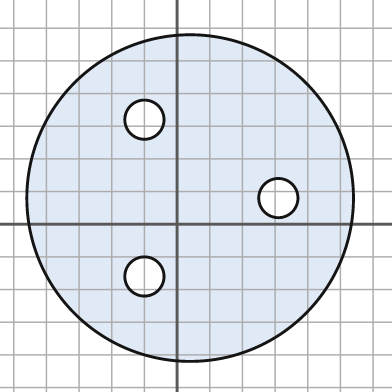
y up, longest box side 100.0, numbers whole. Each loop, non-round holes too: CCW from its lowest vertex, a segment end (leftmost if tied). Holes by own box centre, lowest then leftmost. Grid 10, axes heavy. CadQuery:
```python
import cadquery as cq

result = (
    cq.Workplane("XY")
    .moveTo(4.0, 8.0)
    .circle(50.0)
    .moveTo(-10.0, -16.0)
    .circle(6.0)
    .moveTo(31.0, 8.0)
    .circle(6.0)
    .moveTo(-10.0, 32.0)
    .circle(6.0)
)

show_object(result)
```